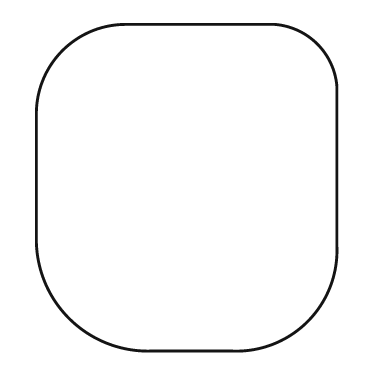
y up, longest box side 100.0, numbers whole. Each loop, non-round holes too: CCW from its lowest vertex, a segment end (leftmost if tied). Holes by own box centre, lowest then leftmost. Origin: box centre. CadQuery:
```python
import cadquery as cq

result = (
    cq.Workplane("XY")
    .moveTo(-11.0, -50.0)
    .lineTo(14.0, -50.0)
    .threePointArc((37.0, -41.0), (46.0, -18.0))
    .lineTo(46.0, 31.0)
    .threePointArc((40.0, 44.0), (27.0, 50.0))
    .lineTo(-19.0, 50.0)
    .threePointArc((-38.0, 42.0), (-46.0, 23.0))
    .lineTo(-46.0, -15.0)
    .threePointArc((-36.0, -40.0), (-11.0, -50.0))
    .close()
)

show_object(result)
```